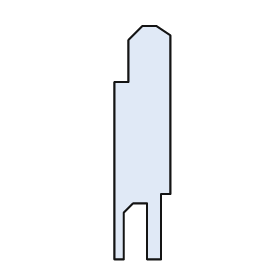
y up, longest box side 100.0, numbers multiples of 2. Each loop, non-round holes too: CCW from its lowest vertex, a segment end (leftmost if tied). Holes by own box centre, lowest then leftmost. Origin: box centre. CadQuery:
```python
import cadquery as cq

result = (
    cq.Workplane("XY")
    .moveTo(-12.0, -50.0)
    .lineTo(-8.0, -50.0)
    .lineTo(-8.0, -30.0)
    .lineTo(-4.0, -26.0)
    .lineTo(2.0, -26.0)
    .lineTo(2.0, -50.0)
    .lineTo(8.0, -50.0)
    .lineTo(8.0, -22.0)
    .lineTo(12.0, -22.0)
    .lineTo(12.0, 46.0)
    .lineTo(6.0, 50.0)
    .lineTo(0.0, 50.0)
    .lineTo(-6.0, 44.0)
    .lineTo(-6.0, 26.0)
    .lineTo(-12.0, 26.0)
    .close()
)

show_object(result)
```